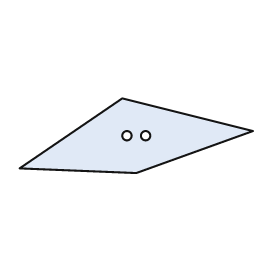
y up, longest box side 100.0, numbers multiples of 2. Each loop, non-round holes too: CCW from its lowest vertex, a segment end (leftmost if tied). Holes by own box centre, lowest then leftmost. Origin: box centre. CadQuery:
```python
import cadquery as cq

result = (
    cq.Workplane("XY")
    .moveTo(0.0, -16.0)
    .lineTo(50.0, 2.0)
    .lineTo(-6.0, 16.0)
    .lineTo(-50.0, -14.0)
    .close()
    .moveTo(-4.0, 0.0)
    .circle(2.0)
    .moveTo(4.0, 0.0)
    .circle(2.0)
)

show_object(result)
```